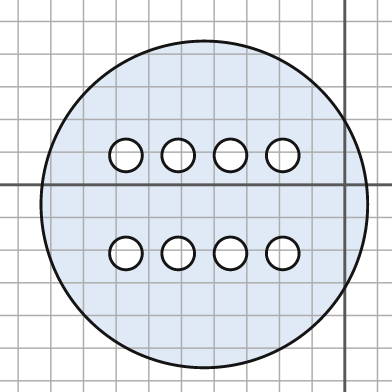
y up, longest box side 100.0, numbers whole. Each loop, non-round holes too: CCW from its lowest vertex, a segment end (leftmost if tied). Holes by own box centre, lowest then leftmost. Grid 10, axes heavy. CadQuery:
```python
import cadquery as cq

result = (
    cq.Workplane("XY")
    .moveTo(-43.0, -6.0)
    .circle(50.0)
    .moveTo(-67.0, -21.0)
    .circle(5.0)
    .moveTo(-51.0, -21.0)
    .circle(5.0)
    .moveTo(-35.0, -21.0)
    .circle(5.0)
    .moveTo(-19.0, -21.0)
    .circle(5.0)
    .moveTo(-67.0, 9.0)
    .circle(5.0)
    .moveTo(-51.0, 9.0)
    .circle(5.0)
    .moveTo(-35.0, 9.0)
    .circle(5.0)
    .moveTo(-19.0, 9.0)
    .circle(5.0)
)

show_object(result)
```